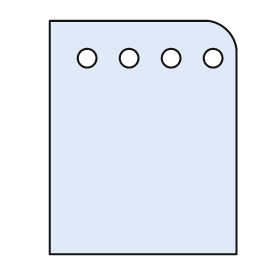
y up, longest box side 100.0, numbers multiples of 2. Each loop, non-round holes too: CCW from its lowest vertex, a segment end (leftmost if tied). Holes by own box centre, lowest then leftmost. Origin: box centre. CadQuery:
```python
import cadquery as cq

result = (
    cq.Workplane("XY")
    .moveTo(-40.0, -50.0)
    .lineTo(40.0, -50.0)
    .lineTo(40.0, 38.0)
    .threePointArc((36.0, 46.0), (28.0, 50.0))
    .lineTo(-40.0, 50.0)
    .close()
    .moveTo(-24.0, 34.0)
    .circle(4.0)
    .moveTo(-6.0, 34.0)
    .circle(4.0)
    .moveTo(12.0, 34.0)
    .circle(4.0)
    .moveTo(30.0, 34.0)
    .circle(4.0)
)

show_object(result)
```